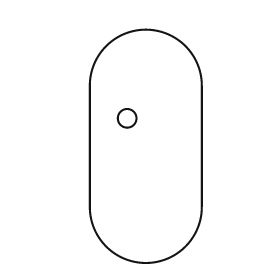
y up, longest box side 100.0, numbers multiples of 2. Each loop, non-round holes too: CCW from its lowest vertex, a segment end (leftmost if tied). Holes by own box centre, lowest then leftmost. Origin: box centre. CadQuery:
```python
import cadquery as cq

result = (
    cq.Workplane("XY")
    .moveTo(-24.0, -26.0)
    .threePointArc((0.0, -50.0), (24.0, -26.0))
    .lineTo(24.0, 26.0)
    .threePointArc((0.0, 50.0), (-24.0, 26.0))
    .close()
    .moveTo(-8.0, 12.0)
    .circle(4.0)
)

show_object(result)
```